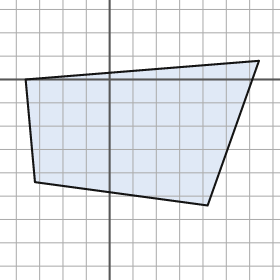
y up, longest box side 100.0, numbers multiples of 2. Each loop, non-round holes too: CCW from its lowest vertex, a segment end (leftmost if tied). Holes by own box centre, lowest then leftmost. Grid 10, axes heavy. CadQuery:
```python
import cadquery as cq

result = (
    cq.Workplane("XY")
    .moveTo(42.0, -54.0)
    .lineTo(64.0, 8.0)
    .lineTo(-36.0, 0.0)
    .lineTo(-32.0, -44.0)
    .close()
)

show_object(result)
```